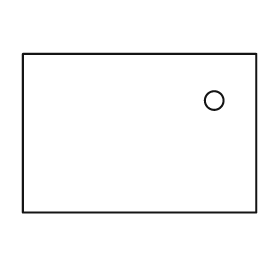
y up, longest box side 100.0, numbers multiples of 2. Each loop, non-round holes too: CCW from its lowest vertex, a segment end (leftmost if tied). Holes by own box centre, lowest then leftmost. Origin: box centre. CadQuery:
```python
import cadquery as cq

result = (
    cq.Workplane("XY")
    .moveTo(-50.0, -34.0)
    .lineTo(50.0, -34.0)
    .lineTo(50.0, 34.0)
    .lineTo(-50.0, 34.0)
    .close()
    .moveTo(32.0, 14.0)
    .circle(4.0)
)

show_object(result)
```